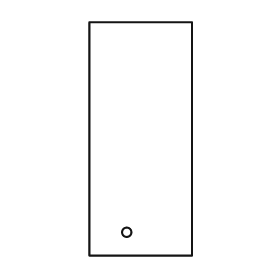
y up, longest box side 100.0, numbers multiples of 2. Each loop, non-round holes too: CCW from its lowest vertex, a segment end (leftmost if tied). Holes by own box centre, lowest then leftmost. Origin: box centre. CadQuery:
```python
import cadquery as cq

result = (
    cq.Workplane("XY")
    .moveTo(-22.0, -50.0)
    .lineTo(22.0, -50.0)
    .lineTo(22.0, 50.0)
    .lineTo(-22.0, 50.0)
    .close()
    .moveTo(-6.0, -40.0)
    .circle(2.0)
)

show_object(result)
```